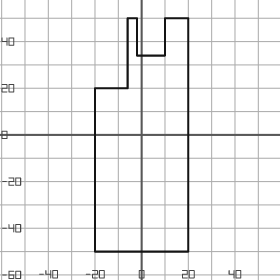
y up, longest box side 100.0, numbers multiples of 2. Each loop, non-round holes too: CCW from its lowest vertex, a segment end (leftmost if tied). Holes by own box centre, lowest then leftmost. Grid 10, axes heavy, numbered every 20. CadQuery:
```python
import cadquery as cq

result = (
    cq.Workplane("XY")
    .moveTo(-20.0, -50.0)
    .lineTo(20.0, -50.0)
    .lineTo(20.0, 50.0)
    .lineTo(10.0, 50.0)
    .lineTo(10.0, 34.0)
    .lineTo(-2.0, 34.0)
    .lineTo(-2.0, 50.0)
    .lineTo(-6.0, 50.0)
    .lineTo(-6.0, 20.0)
    .lineTo(-20.0, 20.0)
    .close()
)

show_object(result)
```